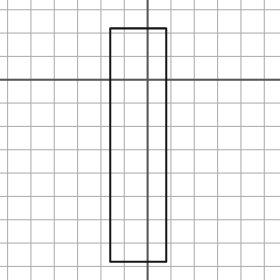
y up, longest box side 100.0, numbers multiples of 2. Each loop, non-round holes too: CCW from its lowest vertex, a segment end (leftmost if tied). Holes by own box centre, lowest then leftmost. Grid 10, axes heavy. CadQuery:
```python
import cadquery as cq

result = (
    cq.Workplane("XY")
    .moveTo(-16.0, -78.0)
    .lineTo(8.0, -78.0)
    .lineTo(8.0, 22.0)
    .lineTo(-16.0, 22.0)
    .close()
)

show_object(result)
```